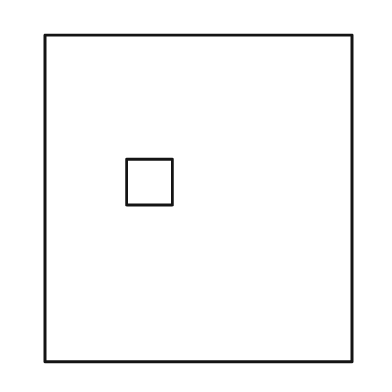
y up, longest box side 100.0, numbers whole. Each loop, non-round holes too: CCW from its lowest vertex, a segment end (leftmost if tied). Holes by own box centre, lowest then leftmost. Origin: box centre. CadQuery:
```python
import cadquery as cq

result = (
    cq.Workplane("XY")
    .moveTo(-47.0, -50.0)
    .lineTo(47.0, -50.0)
    .lineTo(47.0, 50.0)
    .lineTo(-47.0, 50.0)
    .close()
    .moveTo(-22.0, -2.0)
    .lineTo(-8.0, -2.0)
    .lineTo(-8.0, 12.0)
    .lineTo(-22.0, 12.0)
    .close()
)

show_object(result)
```